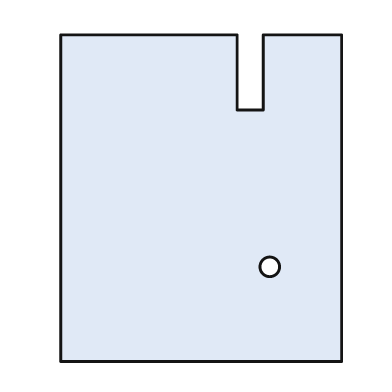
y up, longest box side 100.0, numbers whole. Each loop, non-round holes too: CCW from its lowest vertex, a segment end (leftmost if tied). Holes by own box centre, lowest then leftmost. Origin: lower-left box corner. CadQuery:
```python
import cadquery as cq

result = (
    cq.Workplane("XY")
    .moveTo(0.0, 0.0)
    .lineTo(86.0, 0.0)
    .lineTo(86.0, 100.0)
    .lineTo(62.0, 100.0)
    .lineTo(62.0, 77.0)
    .lineTo(54.0, 77.0)
    .lineTo(54.0, 100.0)
    .lineTo(0.0, 100.0)
    .close()
    .moveTo(64.0, 29.0)
    .circle(3.0)
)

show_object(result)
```